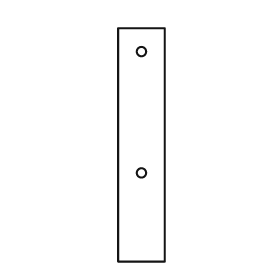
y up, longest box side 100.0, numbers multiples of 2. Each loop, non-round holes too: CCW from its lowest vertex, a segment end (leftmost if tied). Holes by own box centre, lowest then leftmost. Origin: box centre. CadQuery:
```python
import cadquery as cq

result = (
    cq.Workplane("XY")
    .moveTo(-10.0, -50.0)
    .lineTo(10.0, -50.0)
    .lineTo(10.0, 50.0)
    .lineTo(-10.0, 50.0)
    .close()
    .moveTo(0.0, -12.0)
    .circle(2.0)
    .moveTo(0.0, 40.0)
    .circle(2.0)
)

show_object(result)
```